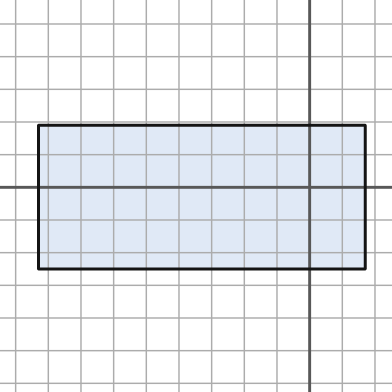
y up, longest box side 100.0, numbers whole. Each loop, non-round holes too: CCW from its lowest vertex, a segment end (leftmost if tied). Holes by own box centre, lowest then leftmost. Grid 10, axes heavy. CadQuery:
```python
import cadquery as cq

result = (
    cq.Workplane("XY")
    .moveTo(-83.0, -25.0)
    .lineTo(17.0, -25.0)
    .lineTo(17.0, 19.0)
    .lineTo(-83.0, 19.0)
    .close()
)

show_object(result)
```